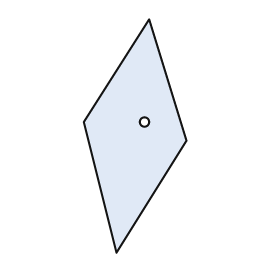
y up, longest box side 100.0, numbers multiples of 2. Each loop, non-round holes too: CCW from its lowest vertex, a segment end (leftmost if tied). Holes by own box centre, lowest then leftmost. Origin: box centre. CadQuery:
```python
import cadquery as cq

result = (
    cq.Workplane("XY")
    .moveTo(-8.0, -50.0)
    .lineTo(22.0, -2.0)
    .lineTo(6.0, 50.0)
    .lineTo(-22.0, 6.0)
    .close()
    .moveTo(4.0, 6.0)
    .circle(2.0)
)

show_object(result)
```